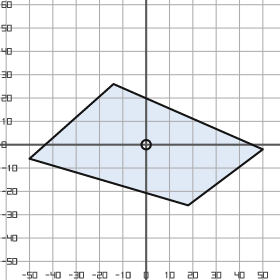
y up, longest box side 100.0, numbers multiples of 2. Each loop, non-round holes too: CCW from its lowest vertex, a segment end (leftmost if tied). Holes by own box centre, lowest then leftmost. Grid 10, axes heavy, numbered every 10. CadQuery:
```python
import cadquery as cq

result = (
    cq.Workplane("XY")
    .moveTo(18.0, -26.0)
    .lineTo(50.0, -2.0)
    .lineTo(-14.0, 26.0)
    .lineTo(-50.0, -6.0)
    .close()
    .moveTo(0.0, 0.0)
    .circle(2.0)
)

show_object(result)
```